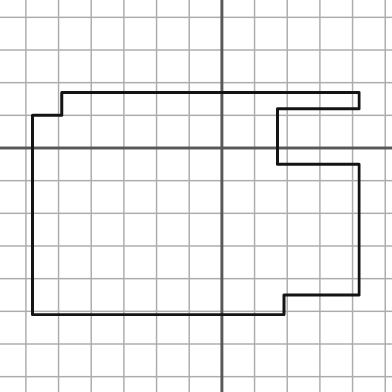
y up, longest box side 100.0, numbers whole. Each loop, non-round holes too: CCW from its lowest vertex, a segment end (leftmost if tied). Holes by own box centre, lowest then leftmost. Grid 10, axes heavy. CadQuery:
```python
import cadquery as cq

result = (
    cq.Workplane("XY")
    .moveTo(-58.0, -51.0)
    .lineTo(19.0, -51.0)
    .lineTo(19.0, -45.0)
    .lineTo(42.0, -45.0)
    .lineTo(42.0, -5.0)
    .lineTo(17.0, -5.0)
    .lineTo(17.0, 12.0)
    .lineTo(42.0, 12.0)
    .lineTo(42.0, 17.0)
    .lineTo(-49.0, 17.0)
    .lineTo(-49.0, 10.0)
    .lineTo(-58.0, 10.0)
    .close()
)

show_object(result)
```